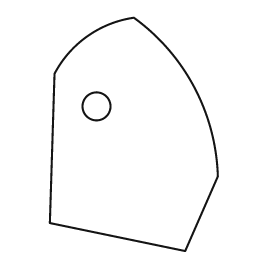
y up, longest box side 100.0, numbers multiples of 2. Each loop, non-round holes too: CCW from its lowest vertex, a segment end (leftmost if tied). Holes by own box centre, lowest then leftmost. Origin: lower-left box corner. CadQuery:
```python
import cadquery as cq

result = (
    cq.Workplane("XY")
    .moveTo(58.0, 0.0)
    .lineTo(72.0, 32.0)
    .threePointArc((62.0, 70.0), (36.0, 100.0))
    .threePointArc((16.0, 92.0), (2.0, 76.0))
    .lineTo(0.0, 12.0)
    .close()
    .moveTo(20.0, 62.0)
    .circle(6.0)
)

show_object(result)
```